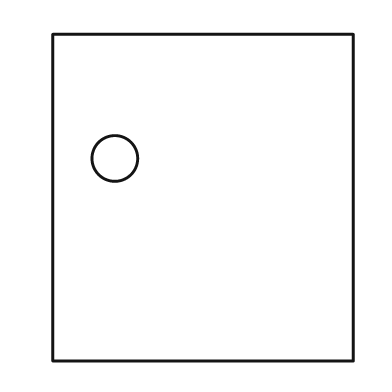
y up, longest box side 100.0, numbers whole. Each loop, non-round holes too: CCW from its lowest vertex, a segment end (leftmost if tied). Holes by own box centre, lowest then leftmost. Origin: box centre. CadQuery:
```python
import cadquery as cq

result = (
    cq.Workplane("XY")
    .moveTo(-46.0, -50.0)
    .lineTo(46.0, -50.0)
    .lineTo(46.0, 50.0)
    .lineTo(-46.0, 50.0)
    .close()
    .moveTo(-27.0, 12.0)
    .circle(7.0)
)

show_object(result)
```